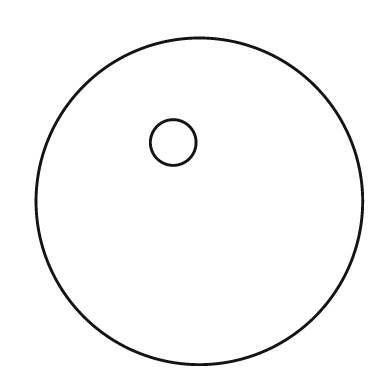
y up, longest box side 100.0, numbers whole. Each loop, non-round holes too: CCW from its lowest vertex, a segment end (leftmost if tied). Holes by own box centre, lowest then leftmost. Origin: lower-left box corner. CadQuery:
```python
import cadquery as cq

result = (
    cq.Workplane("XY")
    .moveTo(50.0, 50.0)
    .circle(50.0)
    .moveTo(42.0, 68.0)
    .circle(7.0)
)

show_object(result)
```